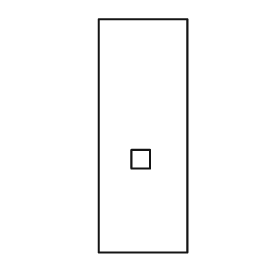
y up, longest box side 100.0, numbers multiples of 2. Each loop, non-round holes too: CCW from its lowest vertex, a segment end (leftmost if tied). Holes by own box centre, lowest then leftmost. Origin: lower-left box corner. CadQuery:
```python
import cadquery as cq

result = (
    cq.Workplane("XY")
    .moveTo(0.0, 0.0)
    .lineTo(38.0, 0.0)
    .lineTo(38.0, 100.0)
    .lineTo(0.0, 100.0)
    .close()
    .moveTo(14.0, 36.0)
    .lineTo(22.0, 36.0)
    .lineTo(22.0, 44.0)
    .lineTo(14.0, 44.0)
    .close()
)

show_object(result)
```